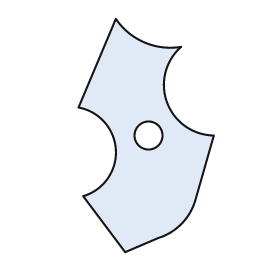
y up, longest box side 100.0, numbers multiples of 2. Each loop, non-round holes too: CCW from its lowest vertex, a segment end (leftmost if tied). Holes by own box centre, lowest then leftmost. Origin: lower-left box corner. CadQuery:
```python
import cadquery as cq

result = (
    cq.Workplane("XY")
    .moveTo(20.0, 0.0)
    .lineTo(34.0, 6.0)
    .threePointArc((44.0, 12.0), (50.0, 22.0))
    .lineTo(58.0, 50.0)
    .threePointArc((38.0, 64.0), (44.0, 88.0))
    .threePointArc((28.0, 90.0), (16.0, 100.0))
    .lineTo(0.0, 62.0)
    .threePointArc((16.0, 44.0), (2.0, 24.0))
    .close()
    .moveTo(30.0, 50.0)
    .circle(6.0)
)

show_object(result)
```